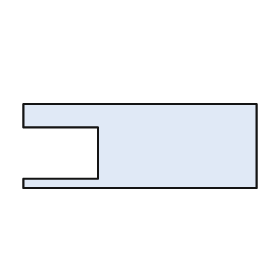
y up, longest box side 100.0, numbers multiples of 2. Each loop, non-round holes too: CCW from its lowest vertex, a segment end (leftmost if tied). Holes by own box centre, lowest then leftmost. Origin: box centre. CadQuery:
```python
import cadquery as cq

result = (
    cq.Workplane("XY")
    .moveTo(-50.0, -18.0)
    .lineTo(50.0, -18.0)
    .lineTo(50.0, 18.0)
    .lineTo(-50.0, 18.0)
    .lineTo(-50.0, 8.0)
    .lineTo(-18.0, 8.0)
    .lineTo(-18.0, -14.0)
    .lineTo(-50.0, -14.0)
    .close()
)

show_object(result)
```